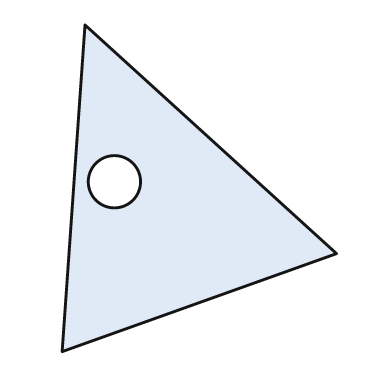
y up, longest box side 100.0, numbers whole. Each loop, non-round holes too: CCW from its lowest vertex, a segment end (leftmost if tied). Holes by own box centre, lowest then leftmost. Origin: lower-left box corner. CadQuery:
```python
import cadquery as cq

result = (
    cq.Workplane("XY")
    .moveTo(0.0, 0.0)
    .lineTo(84.0, 30.0)
    .lineTo(7.0, 100.0)
    .close()
    .moveTo(16.0, 52.0)
    .circle(8.0)
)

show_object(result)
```